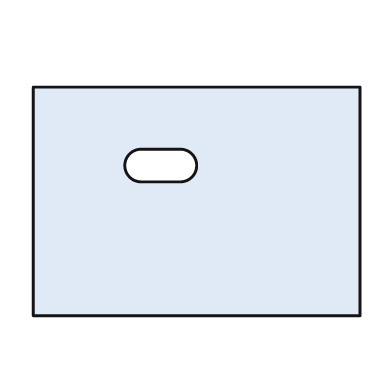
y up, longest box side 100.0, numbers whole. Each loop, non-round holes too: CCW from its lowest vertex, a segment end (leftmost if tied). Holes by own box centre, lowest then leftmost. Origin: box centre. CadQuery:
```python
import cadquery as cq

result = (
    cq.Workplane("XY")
    .moveTo(-50.0, -35.0)
    .lineTo(50.0, -35.0)
    .lineTo(50.0, 35.0)
    .lineTo(-50.0, 35.0)
    .close()
    .moveTo(-17.0, 6.0)
    .lineTo(-5.0, 6.0)
    .threePointArc((0.0, 11.0), (-5.0, 16.0))
    .lineTo(-17.0, 16.0)
    .threePointArc((-22.0, 11.0), (-17.0, 6.0))
    .close()
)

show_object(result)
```